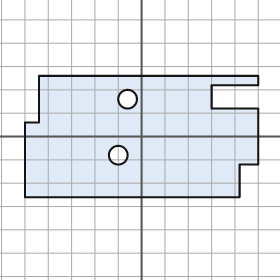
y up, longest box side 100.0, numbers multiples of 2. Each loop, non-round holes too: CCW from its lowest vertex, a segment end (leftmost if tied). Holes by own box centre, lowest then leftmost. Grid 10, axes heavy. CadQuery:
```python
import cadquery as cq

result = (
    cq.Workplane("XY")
    .moveTo(-50.0, -26.0)
    .lineTo(42.0, -26.0)
    .lineTo(42.0, -12.0)
    .lineTo(50.0, -12.0)
    .lineTo(50.0, 12.0)
    .lineTo(30.0, 12.0)
    .lineTo(30.0, 22.0)
    .lineTo(50.0, 22.0)
    .lineTo(50.0, 26.0)
    .lineTo(-44.0, 26.0)
    .lineTo(-44.0, 6.0)
    .lineTo(-50.0, 6.0)
    .close()
    .moveTo(-10.0, -8.0)
    .circle(4.0)
    .moveTo(-6.0, 16.0)
    .circle(4.0)
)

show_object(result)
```